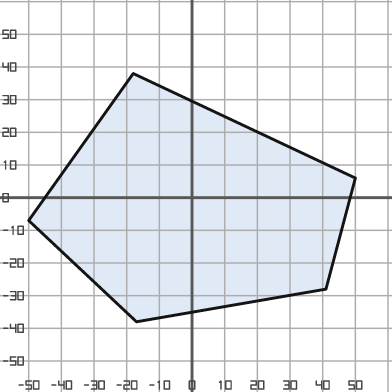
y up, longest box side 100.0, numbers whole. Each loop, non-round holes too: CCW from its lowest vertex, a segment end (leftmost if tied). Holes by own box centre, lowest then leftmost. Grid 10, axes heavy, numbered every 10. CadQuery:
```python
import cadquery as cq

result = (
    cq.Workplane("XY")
    .moveTo(-17.0, -38.0)
    .lineTo(41.0, -28.0)
    .lineTo(50.0, 6.0)
    .lineTo(-18.0, 38.0)
    .lineTo(-50.0, -7.0)
    .close()
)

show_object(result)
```